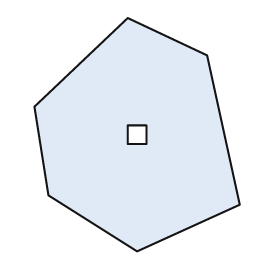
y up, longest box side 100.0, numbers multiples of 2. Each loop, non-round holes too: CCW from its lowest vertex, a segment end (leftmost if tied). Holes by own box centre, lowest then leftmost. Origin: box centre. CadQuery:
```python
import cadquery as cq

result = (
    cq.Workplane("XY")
    .moveTo(0.0, -50.0)
    .lineTo(44.0, -30.0)
    .lineTo(30.0, 34.0)
    .lineTo(-4.0, 50.0)
    .lineTo(-44.0, 12.0)
    .lineTo(-38.0, -26.0)
    .close()
    .moveTo(-4.0, -4.0)
    .lineTo(4.0, -4.0)
    .lineTo(4.0, 4.0)
    .lineTo(-4.0, 4.0)
    .close()
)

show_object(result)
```